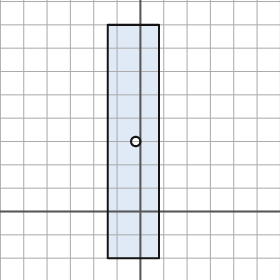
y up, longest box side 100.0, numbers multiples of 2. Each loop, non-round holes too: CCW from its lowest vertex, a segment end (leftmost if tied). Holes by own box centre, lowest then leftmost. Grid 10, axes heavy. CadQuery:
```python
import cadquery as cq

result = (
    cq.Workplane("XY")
    .moveTo(-14.0, -20.0)
    .lineTo(8.0, -20.0)
    .lineTo(8.0, 80.0)
    .lineTo(-14.0, 80.0)
    .close()
    .moveTo(-2.0, 30.0)
    .circle(2.0)
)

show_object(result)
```